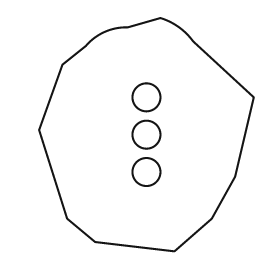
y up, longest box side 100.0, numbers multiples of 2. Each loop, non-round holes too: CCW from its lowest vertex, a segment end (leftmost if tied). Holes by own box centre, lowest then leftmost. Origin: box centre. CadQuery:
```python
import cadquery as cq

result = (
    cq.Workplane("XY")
    .moveTo(12.0, -50.0)
    .lineTo(28.0, -36.0)
    .lineTo(38.0, -18.0)
    .lineTo(46.0, 16.0)
    .lineTo(20.0, 40.0)
    .threePointArc((14.0, 46.0), (6.0, 50.0))
    .lineTo(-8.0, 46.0)
    .threePointArc((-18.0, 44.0), (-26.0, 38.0))
    .lineTo(-36.0, 30.0)
    .lineTo(-46.0, 2.0)
    .lineTo(-34.0, -36.0)
    .lineTo(-22.0, -46.0)
    .close()
    .moveTo(0.0, -16.0)
    .circle(6.0)
    .moveTo(0.0, 0.0)
    .circle(6.0)
    .moveTo(0.0, 16.0)
    .circle(6.0)
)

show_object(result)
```